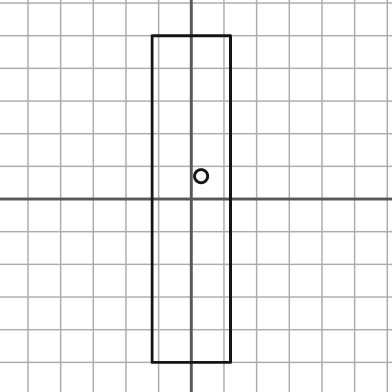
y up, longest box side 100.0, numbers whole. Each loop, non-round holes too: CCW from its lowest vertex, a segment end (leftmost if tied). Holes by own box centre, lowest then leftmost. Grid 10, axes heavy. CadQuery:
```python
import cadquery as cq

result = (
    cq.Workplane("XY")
    .moveTo(-12.0, -50.0)
    .lineTo(12.0, -50.0)
    .lineTo(12.0, 50.0)
    .lineTo(-12.0, 50.0)
    .close()
    .moveTo(3.0, 7.0)
    .circle(2.0)
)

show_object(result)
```